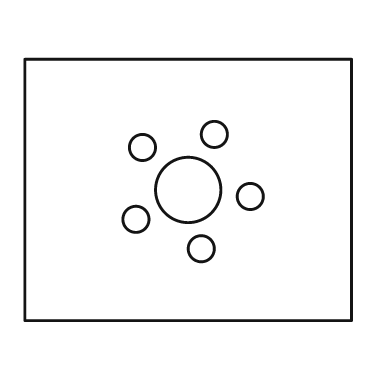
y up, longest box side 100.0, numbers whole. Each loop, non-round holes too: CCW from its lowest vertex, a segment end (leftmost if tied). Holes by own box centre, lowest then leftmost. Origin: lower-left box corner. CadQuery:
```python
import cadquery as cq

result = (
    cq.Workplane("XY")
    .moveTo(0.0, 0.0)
    .lineTo(100.0, 0.0)
    .lineTo(100.0, 80.0)
    .lineTo(0.0, 80.0)
    .close()
    .moveTo(54.0, 22.0)
    .circle(4.0)
    .moveTo(34.0, 31.0)
    .circle(4.0)
    .moveTo(69.0, 38.0)
    .circle(4.0)
    .moveTo(50.0, 40.0)
    .circle(10.0)
    .moveTo(36.0, 53.0)
    .circle(4.0)
    .moveTo(58.0, 57.0)
    .circle(4.0)
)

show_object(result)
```